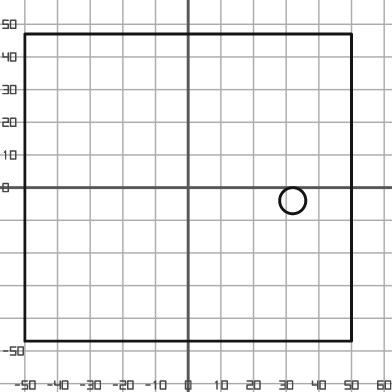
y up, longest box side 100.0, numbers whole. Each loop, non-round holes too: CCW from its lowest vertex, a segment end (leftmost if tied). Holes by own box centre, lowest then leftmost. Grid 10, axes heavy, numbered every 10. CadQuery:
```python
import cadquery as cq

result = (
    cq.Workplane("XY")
    .moveTo(-50.0, -47.0)
    .lineTo(50.0, -47.0)
    .lineTo(50.0, 47.0)
    .lineTo(-50.0, 47.0)
    .close()
    .moveTo(32.0, -4.0)
    .circle(4.0)
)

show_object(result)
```